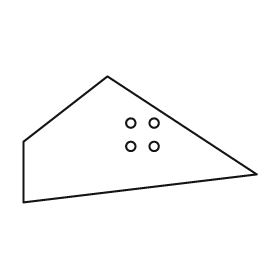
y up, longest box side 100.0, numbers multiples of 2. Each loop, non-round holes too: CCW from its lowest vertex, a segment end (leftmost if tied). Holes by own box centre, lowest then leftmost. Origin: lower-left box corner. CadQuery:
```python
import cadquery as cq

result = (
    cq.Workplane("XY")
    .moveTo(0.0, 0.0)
    .lineTo(100.0, 12.0)
    .lineTo(36.0, 54.0)
    .lineTo(0.0, 26.0)
    .close()
    .moveTo(46.0, 24.0)
    .circle(2.0)
    .moveTo(56.0, 24.0)
    .circle(2.0)
    .moveTo(46.0, 34.0)
    .circle(2.0)
    .moveTo(56.0, 34.0)
    .circle(2.0)
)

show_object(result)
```